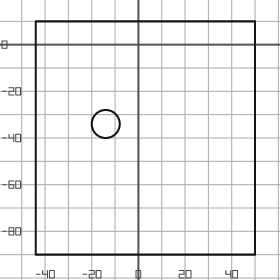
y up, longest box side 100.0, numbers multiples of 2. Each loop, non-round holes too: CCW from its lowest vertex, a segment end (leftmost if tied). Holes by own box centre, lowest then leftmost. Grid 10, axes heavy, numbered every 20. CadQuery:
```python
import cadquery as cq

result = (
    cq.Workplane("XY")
    .moveTo(-44.0, -90.0)
    .lineTo(50.0, -90.0)
    .lineTo(50.0, 10.0)
    .lineTo(-44.0, 10.0)
    .close()
    .moveTo(-14.0, -34.0)
    .circle(6.0)
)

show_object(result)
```